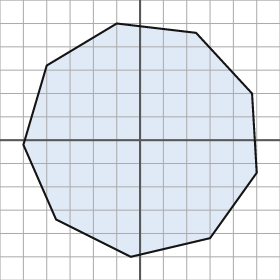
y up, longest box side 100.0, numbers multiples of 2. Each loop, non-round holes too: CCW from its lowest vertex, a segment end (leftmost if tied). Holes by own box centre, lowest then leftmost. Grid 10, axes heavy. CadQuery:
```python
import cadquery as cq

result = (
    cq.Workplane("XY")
    .moveTo(-4.0, -50.0)
    .lineTo(30.0, -42.0)
    .lineTo(50.0, -14.0)
    .lineTo(48.0, 20.0)
    .lineTo(24.0, 46.0)
    .lineTo(-10.0, 50.0)
    .lineTo(-40.0, 32.0)
    .lineTo(-50.0, -2.0)
    .lineTo(-36.0, -34.0)
    .close()
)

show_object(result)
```